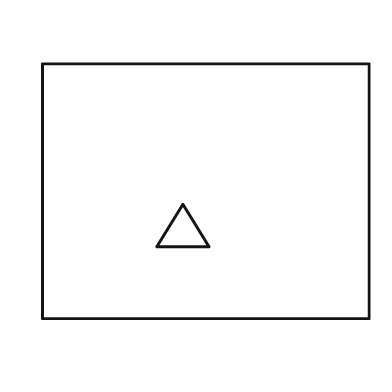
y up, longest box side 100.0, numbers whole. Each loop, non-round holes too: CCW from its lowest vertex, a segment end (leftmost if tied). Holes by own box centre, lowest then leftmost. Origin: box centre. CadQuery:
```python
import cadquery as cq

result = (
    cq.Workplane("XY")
    .moveTo(-50.0, -39.0)
    .lineTo(50.0, -39.0)
    .lineTo(50.0, 39.0)
    .lineTo(-50.0, 39.0)
    .close()
    .moveTo(-15.0, -17.0)
    .lineTo(1.0, -17.0)
    .lineTo(-7.0, -4.0)
    .close()
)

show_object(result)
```